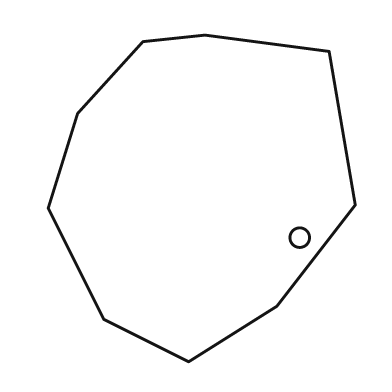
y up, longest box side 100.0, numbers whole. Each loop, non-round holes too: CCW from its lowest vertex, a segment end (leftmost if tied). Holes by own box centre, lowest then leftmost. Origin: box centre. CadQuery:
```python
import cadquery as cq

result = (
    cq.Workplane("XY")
    .moveTo(-4.0, -50.0)
    .lineTo(23.0, -33.0)
    .lineTo(47.0, -2.0)
    .lineTo(39.0, 45.0)
    .lineTo(1.0, 50.0)
    .lineTo(-18.0, 48.0)
    .lineTo(-38.0, 26.0)
    .lineTo(-47.0, -3.0)
    .lineTo(-30.0, -37.0)
    .close()
    .moveTo(30.0, -12.0)
    .circle(3.0)
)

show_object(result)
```